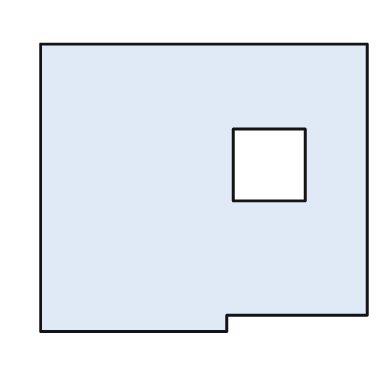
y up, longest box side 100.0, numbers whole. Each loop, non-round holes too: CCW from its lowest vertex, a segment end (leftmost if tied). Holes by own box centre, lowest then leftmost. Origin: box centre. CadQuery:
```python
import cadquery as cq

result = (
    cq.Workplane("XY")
    .moveTo(-50.0, -44.0)
    .lineTo(7.0, -44.0)
    .lineTo(7.0, -39.0)
    .lineTo(50.0, -39.0)
    .lineTo(50.0, 44.0)
    .lineTo(-50.0, 44.0)
    .close()
    .moveTo(9.0, -4.0)
    .lineTo(31.0, -4.0)
    .lineTo(31.0, 18.0)
    .lineTo(9.0, 18.0)
    .close()
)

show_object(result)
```